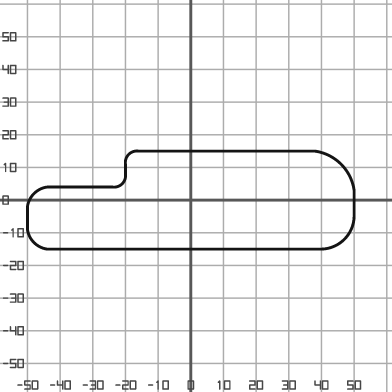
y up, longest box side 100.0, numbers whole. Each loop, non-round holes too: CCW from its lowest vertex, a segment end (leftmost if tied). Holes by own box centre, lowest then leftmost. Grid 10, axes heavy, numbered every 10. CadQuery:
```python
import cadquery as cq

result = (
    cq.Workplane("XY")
    .moveTo(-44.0, -15.0)
    .lineTo(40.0, -15.0)
    .threePointArc((47.0, -12.0), (50.0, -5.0))
    .lineTo(50.0, 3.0)
    .threePointArc((46.0, 11.0), (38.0, 15.0))
    .lineTo(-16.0, 15.0)
    .threePointArc((-19.0, 14.0), (-20.0, 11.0))
    .lineTo(-20.0, 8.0)
    .threePointArc((-21.0, 5.0), (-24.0, 4.0))
    .lineTo(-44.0, 4.0)
    .threePointArc((-48.0, 2.0), (-50.0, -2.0))
    .lineTo(-50.0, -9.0)
    .threePointArc((-48.0, -13.0), (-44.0, -15.0))
    .close()
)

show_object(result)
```